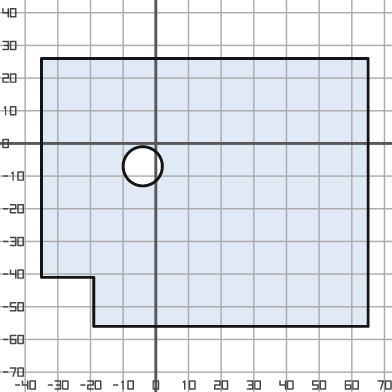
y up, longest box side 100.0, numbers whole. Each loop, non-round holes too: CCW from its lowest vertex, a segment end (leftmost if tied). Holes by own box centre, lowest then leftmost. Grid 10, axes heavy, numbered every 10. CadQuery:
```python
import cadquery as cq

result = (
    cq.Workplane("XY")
    .moveTo(-19.0, -56.0)
    .lineTo(65.0, -56.0)
    .lineTo(65.0, 26.0)
    .lineTo(-35.0, 26.0)
    .lineTo(-35.0, -41.0)
    .lineTo(-19.0, -41.0)
    .close()
    .moveTo(-4.0, -7.0)
    .circle(6.0)
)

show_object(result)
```